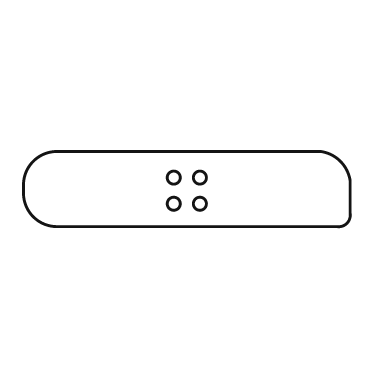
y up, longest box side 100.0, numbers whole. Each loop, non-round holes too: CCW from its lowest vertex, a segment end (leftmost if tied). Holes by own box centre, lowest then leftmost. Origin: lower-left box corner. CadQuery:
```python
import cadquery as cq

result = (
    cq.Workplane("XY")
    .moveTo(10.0, 0.0)
    .lineTo(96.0, 0.0)
    .threePointArc((99.0, 1.0), (100.0, 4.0))
    .lineTo(100.0, 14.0)
    .threePointArc((97.0, 20.0), (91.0, 23.0))
    .lineTo(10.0, 23.0)
    .threePointArc((3.0, 20.0), (0.0, 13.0))
    .lineTo(0.0, 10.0)
    .threePointArc((3.0, 3.0), (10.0, 0.0))
    .close()
    .moveTo(46.0, 7.0)
    .circle(2.0)
    .moveTo(54.0, 7.0)
    .circle(2.0)
    .moveTo(46.0, 15.0)
    .circle(2.0)
    .moveTo(54.0, 15.0)
    .circle(2.0)
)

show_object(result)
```